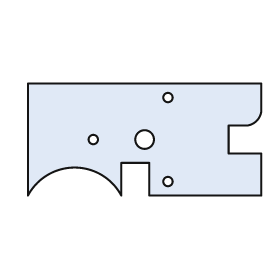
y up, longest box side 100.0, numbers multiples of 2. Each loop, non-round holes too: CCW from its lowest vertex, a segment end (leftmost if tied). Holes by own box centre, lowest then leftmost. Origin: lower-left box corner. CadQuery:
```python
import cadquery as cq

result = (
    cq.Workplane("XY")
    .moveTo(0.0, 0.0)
    .threePointArc((20.0, 12.0), (40.0, 0.0))
    .lineTo(40.0, 14.0)
    .lineTo(52.0, 14.0)
    .lineTo(52.0, 0.0)
    .lineTo(100.0, 0.0)
    .lineTo(100.0, 18.0)
    .lineTo(86.0, 18.0)
    .lineTo(86.0, 30.0)
    .lineTo(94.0, 30.0)
    .threePointArc((98.0, 32.0), (100.0, 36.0))
    .lineTo(100.0, 48.0)
    .lineTo(0.0, 48.0)
    .close()
    .moveTo(60.0, 6.0)
    .circle(2.0)
    .moveTo(28.0, 24.0)
    .circle(2.0)
    .moveTo(50.0, 24.0)
    .circle(4.0)
    .moveTo(60.0, 42.0)
    .circle(2.0)
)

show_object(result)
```